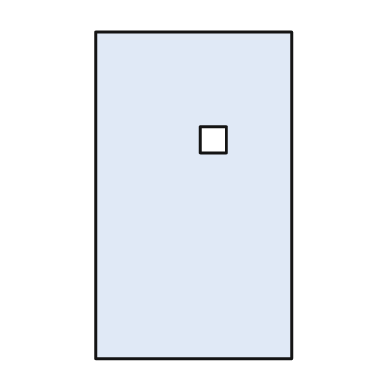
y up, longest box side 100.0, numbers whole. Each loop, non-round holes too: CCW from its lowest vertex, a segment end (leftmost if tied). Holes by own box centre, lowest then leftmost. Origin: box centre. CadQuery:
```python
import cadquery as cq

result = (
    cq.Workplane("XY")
    .moveTo(-30.0, -50.0)
    .lineTo(30.0, -50.0)
    .lineTo(30.0, 50.0)
    .lineTo(-30.0, 50.0)
    .close()
    .moveTo(2.0, 13.0)
    .lineTo(10.0, 13.0)
    .lineTo(10.0, 21.0)
    .lineTo(2.0, 21.0)
    .close()
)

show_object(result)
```